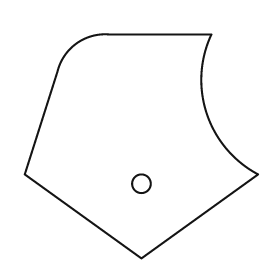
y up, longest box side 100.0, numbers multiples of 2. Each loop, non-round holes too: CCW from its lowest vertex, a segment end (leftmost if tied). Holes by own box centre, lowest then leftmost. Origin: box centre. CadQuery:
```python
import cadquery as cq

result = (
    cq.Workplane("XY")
    .moveTo(0.0, -48.0)
    .lineTo(50.0, -12.0)
    .threePointArc((28.0, 14.0), (30.0, 48.0))
    .lineTo(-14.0, 48.0)
    .threePointArc((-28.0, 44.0), (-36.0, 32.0))
    .lineTo(-50.0, -12.0)
    .close()
    .moveTo(0.0, -16.0)
    .circle(4.0)
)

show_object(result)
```